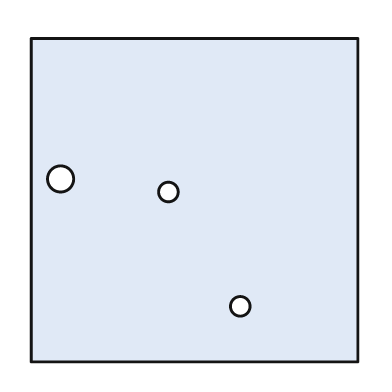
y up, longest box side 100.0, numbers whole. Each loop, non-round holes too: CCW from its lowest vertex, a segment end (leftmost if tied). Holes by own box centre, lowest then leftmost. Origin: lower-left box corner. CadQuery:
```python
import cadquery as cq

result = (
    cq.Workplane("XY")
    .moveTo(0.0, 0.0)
    .lineTo(100.0, 0.0)
    .lineTo(100.0, 99.0)
    .lineTo(0.0, 99.0)
    .close()
    .moveTo(64.0, 17.0)
    .circle(3.0)
    .moveTo(42.0, 52.0)
    .circle(3.0)
    .moveTo(9.0, 56.0)
    .circle(4.0)
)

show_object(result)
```